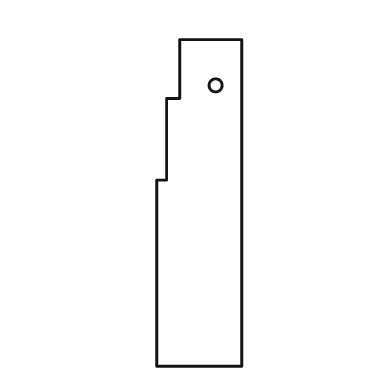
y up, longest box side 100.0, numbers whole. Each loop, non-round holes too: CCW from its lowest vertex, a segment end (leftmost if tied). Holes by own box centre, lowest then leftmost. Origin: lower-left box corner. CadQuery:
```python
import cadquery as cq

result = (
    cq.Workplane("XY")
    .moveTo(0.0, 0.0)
    .lineTo(26.0, 0.0)
    .lineTo(26.0, 100.0)
    .lineTo(7.0, 100.0)
    .lineTo(7.0, 82.0)
    .lineTo(3.0, 82.0)
    .lineTo(3.0, 57.0)
    .lineTo(0.0, 57.0)
    .close()
    .moveTo(18.0, 86.0)
    .circle(2.0)
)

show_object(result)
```